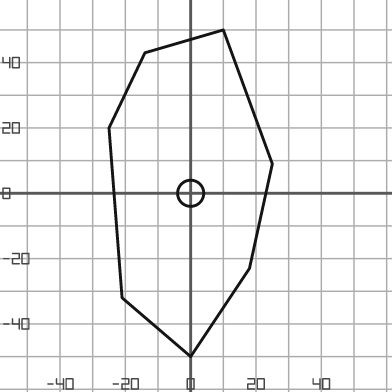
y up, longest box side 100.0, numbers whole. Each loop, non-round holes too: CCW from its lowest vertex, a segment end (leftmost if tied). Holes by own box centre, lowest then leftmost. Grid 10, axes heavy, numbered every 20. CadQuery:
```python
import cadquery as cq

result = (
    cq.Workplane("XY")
    .moveTo(0.0, -50.0)
    .lineTo(18.0, -23.0)
    .lineTo(25.0, 9.0)
    .lineTo(10.0, 50.0)
    .lineTo(-14.0, 43.0)
    .lineTo(-25.0, 20.0)
    .lineTo(-21.0, -32.0)
    .close()
    .moveTo(0.0, 0.0)
    .circle(4.0)
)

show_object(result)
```